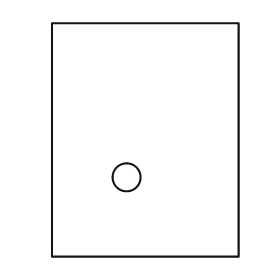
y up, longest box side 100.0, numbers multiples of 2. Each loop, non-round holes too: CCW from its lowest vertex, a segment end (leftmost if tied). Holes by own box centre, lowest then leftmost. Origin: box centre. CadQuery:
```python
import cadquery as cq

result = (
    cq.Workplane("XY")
    .moveTo(-40.0, -50.0)
    .lineTo(40.0, -50.0)
    .lineTo(40.0, 50.0)
    .lineTo(-40.0, 50.0)
    .close()
    .moveTo(-8.0, -16.0)
    .circle(6.0)
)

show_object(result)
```